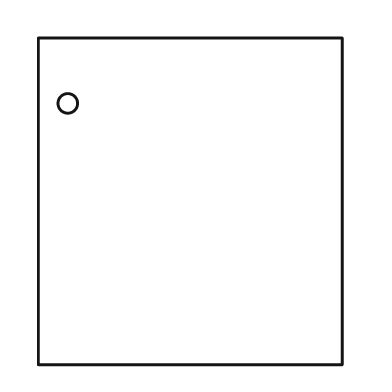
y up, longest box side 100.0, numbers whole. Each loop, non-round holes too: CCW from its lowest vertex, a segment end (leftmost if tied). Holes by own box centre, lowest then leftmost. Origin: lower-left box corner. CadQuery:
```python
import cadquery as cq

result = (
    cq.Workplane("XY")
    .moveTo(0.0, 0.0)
    .lineTo(93.0, 0.0)
    .lineTo(93.0, 100.0)
    .lineTo(0.0, 100.0)
    .close()
    .moveTo(9.0, 80.0)
    .circle(3.0)
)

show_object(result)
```